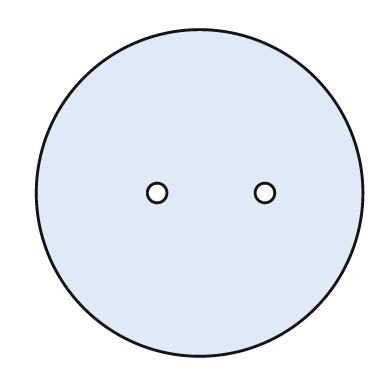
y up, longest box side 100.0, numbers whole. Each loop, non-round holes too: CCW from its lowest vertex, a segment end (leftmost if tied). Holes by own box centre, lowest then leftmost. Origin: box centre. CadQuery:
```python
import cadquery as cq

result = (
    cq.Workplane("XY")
    .moveTo(0.0, 0.0)
    .circle(50.0)
    .moveTo(-13.0, 0.0)
    .circle(3.0)
    .moveTo(20.0, 0.0)
    .circle(3.0)
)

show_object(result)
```